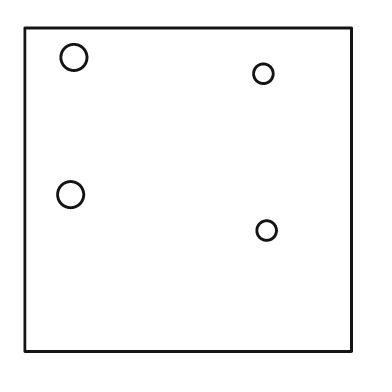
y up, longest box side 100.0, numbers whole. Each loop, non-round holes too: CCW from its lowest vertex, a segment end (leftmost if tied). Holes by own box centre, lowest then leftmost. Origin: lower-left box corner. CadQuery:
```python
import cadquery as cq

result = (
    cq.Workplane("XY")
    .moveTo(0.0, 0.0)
    .lineTo(100.0, 0.0)
    .lineTo(100.0, 99.0)
    .lineTo(0.0, 99.0)
    .close()
    .moveTo(74.0, 37.0)
    .circle(3.0)
    .moveTo(14.0, 48.0)
    .circle(4.0)
    .moveTo(73.0, 85.0)
    .circle(3.0)
    .moveTo(15.0, 90.0)
    .circle(4.0)
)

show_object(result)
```